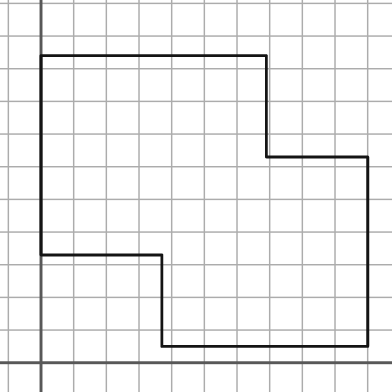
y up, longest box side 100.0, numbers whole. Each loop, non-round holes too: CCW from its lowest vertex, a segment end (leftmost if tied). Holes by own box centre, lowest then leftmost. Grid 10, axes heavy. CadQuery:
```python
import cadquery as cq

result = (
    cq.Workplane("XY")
    .moveTo(37.0, 5.0)
    .lineTo(100.0, 5.0)
    .lineTo(100.0, 63.0)
    .lineTo(69.0, 63.0)
    .lineTo(69.0, 94.0)
    .lineTo(0.0, 94.0)
    .lineTo(0.0, 33.0)
    .lineTo(37.0, 33.0)
    .close()
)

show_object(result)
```